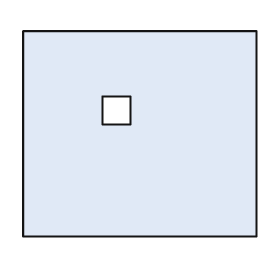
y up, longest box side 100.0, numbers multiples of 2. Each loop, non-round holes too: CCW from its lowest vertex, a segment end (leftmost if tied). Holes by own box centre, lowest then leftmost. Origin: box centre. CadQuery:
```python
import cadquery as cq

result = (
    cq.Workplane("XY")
    .moveTo(-50.0, -44.0)
    .lineTo(50.0, -44.0)
    .lineTo(50.0, 44.0)
    .lineTo(-50.0, 44.0)
    .close()
    .moveTo(-16.0, 4.0)
    .lineTo(-4.0, 4.0)
    .lineTo(-4.0, 16.0)
    .lineTo(-16.0, 16.0)
    .close()
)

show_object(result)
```